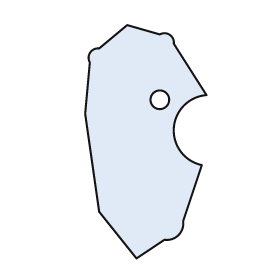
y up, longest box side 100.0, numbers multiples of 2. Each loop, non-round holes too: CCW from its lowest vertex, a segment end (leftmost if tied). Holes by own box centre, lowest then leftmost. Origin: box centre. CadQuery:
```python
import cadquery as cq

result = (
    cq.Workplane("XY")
    .moveTo(-4.0, -50.0)
    .lineTo(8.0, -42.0)
    .threePointArc((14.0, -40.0), (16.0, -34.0))
    .lineTo(24.0, -10.0)
    .threePointArc((12.0, 6.0), (26.0, 20.0))
    .lineTo(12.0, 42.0)
    .threePointArc((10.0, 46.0), (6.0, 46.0))
    .lineTo(-8.0, 50.0)
    .lineTo(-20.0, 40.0)
    .threePointArc((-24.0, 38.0), (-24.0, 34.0))
    .lineTo(-26.0, 12.0)
    .lineTo(-20.0, -30.0)
    .close()
    .moveTo(6.0, 18.0)
    .circle(4.0)
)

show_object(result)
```